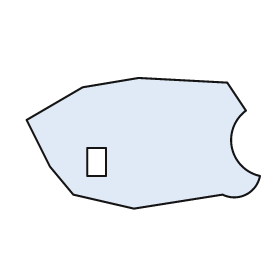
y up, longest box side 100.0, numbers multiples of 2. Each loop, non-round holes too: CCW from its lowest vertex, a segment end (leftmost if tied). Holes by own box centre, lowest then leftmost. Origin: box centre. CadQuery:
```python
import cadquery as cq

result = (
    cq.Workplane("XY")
    .moveTo(-4.0, -28.0)
    .lineTo(34.0, -22.0)
    .threePointArc((44.0, -22.0), (50.0, -14.0))
    .threePointArc((38.0, -2.0), (44.0, 14.0))
    .lineTo(36.0, 26.0)
    .lineTo(-2.0, 28.0)
    .lineTo(-26.0, 24.0)
    .lineTo(-50.0, 10.0)
    .lineTo(-40.0, -10.0)
    .lineTo(-30.0, -22.0)
    .close()
    .moveTo(-24.0, -14.0)
    .lineTo(-16.0, -14.0)
    .lineTo(-16.0, -2.0)
    .lineTo(-24.0, -2.0)
    .close()
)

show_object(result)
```